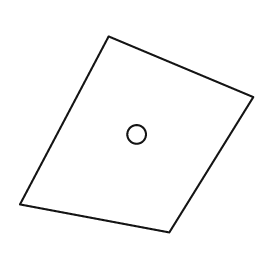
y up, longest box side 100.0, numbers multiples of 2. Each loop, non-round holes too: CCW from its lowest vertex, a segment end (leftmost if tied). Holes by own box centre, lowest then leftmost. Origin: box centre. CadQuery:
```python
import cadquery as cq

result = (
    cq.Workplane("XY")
    .moveTo(14.0, -42.0)
    .lineTo(50.0, 16.0)
    .lineTo(-12.0, 42.0)
    .lineTo(-50.0, -30.0)
    .close()
    .moveTo(0.0, 0.0)
    .circle(4.0)
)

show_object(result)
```